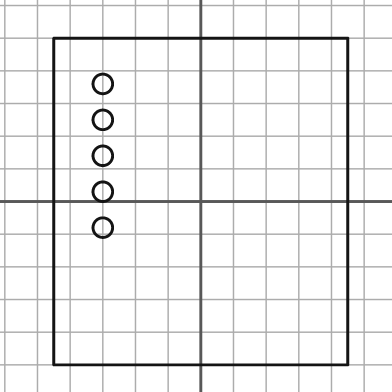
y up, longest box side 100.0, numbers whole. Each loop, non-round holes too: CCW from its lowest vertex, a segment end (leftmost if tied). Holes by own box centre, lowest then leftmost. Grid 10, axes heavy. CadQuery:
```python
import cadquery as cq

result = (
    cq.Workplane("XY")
    .moveTo(-45.0, -50.0)
    .lineTo(45.0, -50.0)
    .lineTo(45.0, 50.0)
    .lineTo(-45.0, 50.0)
    .close()
    .moveTo(-30.0, -8.0)
    .circle(3.0)
    .moveTo(-30.0, 3.0)
    .circle(3.0)
    .moveTo(-30.0, 14.0)
    .circle(3.0)
    .moveTo(-30.0, 25.0)
    .circle(3.0)
    .moveTo(-30.0, 36.0)
    .circle(3.0)
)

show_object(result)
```